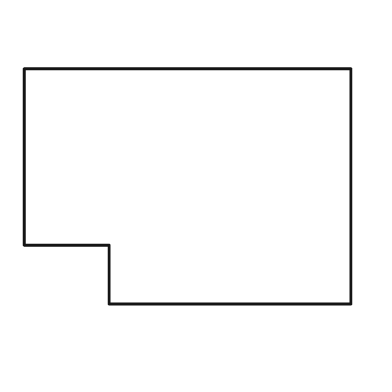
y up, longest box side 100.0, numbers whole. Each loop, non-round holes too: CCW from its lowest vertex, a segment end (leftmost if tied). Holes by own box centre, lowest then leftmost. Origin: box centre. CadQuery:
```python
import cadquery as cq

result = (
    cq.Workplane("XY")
    .moveTo(-24.0, -36.0)
    .lineTo(50.0, -36.0)
    .lineTo(50.0, 36.0)
    .lineTo(-50.0, 36.0)
    .lineTo(-50.0, -18.0)
    .lineTo(-24.0, -18.0)
    .close()
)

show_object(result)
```